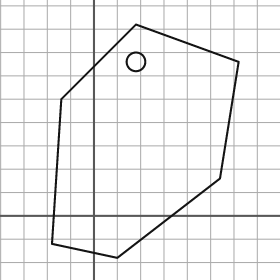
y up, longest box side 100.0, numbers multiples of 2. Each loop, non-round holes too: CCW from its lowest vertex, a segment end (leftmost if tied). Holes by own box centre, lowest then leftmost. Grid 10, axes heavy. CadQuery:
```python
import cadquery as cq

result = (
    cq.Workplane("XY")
    .moveTo(10.0, -18.0)
    .lineTo(54.0, 16.0)
    .lineTo(62.0, 66.0)
    .lineTo(18.0, 82.0)
    .lineTo(-14.0, 50.0)
    .lineTo(-18.0, -12.0)
    .close()
    .moveTo(18.0, 66.0)
    .circle(4.0)
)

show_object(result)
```